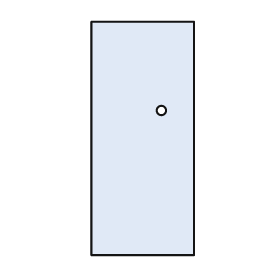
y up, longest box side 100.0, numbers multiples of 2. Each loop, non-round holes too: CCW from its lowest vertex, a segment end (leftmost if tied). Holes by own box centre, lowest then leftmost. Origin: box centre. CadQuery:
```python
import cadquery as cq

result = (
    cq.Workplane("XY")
    .moveTo(-22.0, -50.0)
    .lineTo(22.0, -50.0)
    .lineTo(22.0, 50.0)
    .lineTo(-22.0, 50.0)
    .close()
    .moveTo(8.0, 12.0)
    .circle(2.0)
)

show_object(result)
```